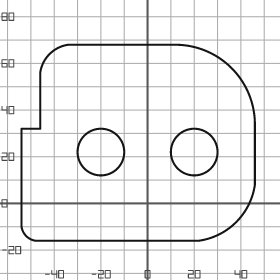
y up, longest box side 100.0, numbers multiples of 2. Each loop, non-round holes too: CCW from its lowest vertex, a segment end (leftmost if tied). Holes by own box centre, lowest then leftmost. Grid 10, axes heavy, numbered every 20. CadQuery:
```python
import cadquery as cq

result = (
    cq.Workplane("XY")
    .moveTo(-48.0, -16.0)
    .lineTo(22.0, -16.0)
    .threePointArc((38.0, -8.0), (46.0, 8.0))
    .lineTo(46.0, 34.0)
    .threePointArc((36.0, 58.0), (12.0, 68.0))
    .lineTo(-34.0, 68.0)
    .threePointArc((-42.0, 64.0), (-46.0, 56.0))
    .lineTo(-46.0, 32.0)
    .lineTo(-54.0, 32.0)
    .lineTo(-54.0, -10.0)
    .threePointArc((-52.0, -14.0), (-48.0, -16.0))
    .close()
    .moveTo(-20.0, 22.0)
    .circle(10.0)
    .moveTo(20.0, 22.0)
    .circle(10.0)
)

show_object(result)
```